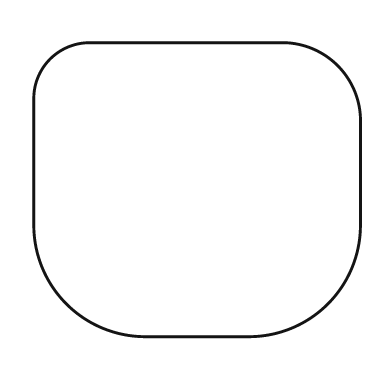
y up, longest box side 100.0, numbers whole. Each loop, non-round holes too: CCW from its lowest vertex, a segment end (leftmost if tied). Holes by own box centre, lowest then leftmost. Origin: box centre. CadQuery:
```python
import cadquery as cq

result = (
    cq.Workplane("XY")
    .moveTo(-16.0, -45.0)
    .lineTo(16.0, -45.0)
    .threePointArc((40.0, -35.0), (50.0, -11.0))
    .lineTo(50.0, 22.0)
    .threePointArc((43.0, 38.0), (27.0, 45.0))
    .lineTo(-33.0, 45.0)
    .threePointArc((-45.0, 40.0), (-50.0, 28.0))
    .lineTo(-50.0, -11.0)
    .threePointArc((-40.0, -35.0), (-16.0, -45.0))
    .close()
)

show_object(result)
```